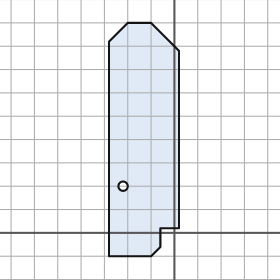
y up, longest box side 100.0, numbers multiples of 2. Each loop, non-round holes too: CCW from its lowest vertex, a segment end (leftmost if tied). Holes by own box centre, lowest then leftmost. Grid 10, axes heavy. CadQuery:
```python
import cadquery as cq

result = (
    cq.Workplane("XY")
    .moveTo(-28.0, -10.0)
    .lineTo(-10.0, -10.0)
    .lineTo(-6.0, -6.0)
    .lineTo(-6.0, 2.0)
    .lineTo(2.0, 2.0)
    .lineTo(2.0, 78.0)
    .lineTo(-10.0, 90.0)
    .lineTo(-20.0, 90.0)
    .lineTo(-28.0, 82.0)
    .close()
    .moveTo(-22.0, 20.0)
    .circle(2.0)
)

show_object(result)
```